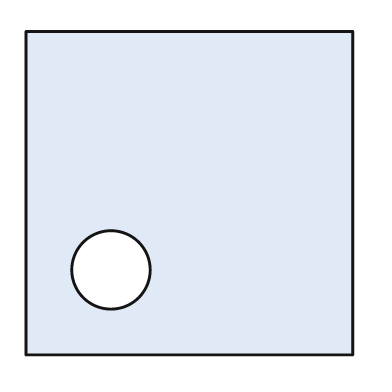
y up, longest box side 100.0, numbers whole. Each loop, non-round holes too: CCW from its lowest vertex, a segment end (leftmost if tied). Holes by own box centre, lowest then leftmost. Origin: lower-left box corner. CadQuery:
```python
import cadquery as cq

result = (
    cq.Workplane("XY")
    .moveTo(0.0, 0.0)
    .lineTo(100.0, 0.0)
    .lineTo(100.0, 99.0)
    .lineTo(0.0, 99.0)
    .close()
    .moveTo(26.0, 26.0)
    .circle(12.0)
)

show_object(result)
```